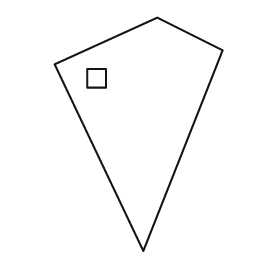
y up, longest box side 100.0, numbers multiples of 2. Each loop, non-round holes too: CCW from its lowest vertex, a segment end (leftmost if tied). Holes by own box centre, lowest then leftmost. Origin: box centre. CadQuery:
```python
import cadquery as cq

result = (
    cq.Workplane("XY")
    .moveTo(2.0, -50.0)
    .lineTo(36.0, 36.0)
    .lineTo(8.0, 50.0)
    .lineTo(-36.0, 30.0)
    .close()
    .moveTo(-22.0, 20.0)
    .lineTo(-14.0, 20.0)
    .lineTo(-14.0, 28.0)
    .lineTo(-22.0, 28.0)
    .close()
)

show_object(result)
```